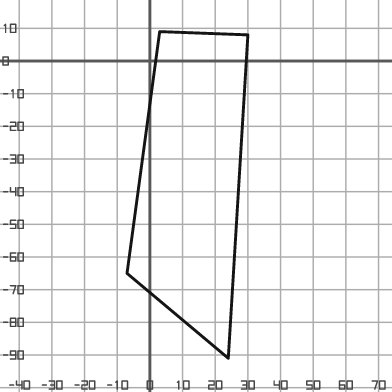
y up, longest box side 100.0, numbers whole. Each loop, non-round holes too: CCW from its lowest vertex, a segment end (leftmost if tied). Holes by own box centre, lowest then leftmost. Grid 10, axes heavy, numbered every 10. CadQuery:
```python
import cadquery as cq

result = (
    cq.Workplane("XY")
    .moveTo(24.0, -91.0)
    .lineTo(30.0, 8.0)
    .lineTo(3.0, 9.0)
    .lineTo(-7.0, -65.0)
    .close()
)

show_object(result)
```